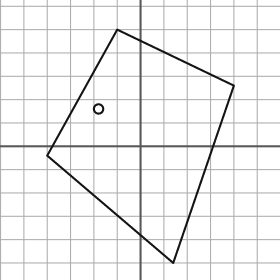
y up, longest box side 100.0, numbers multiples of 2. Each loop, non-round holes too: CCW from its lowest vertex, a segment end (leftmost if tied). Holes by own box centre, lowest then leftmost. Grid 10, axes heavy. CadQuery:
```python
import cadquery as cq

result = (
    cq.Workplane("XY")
    .moveTo(14.0, -50.0)
    .lineTo(40.0, 26.0)
    .lineTo(-10.0, 50.0)
    .lineTo(-40.0, -4.0)
    .close()
    .moveTo(-18.0, 16.0)
    .circle(2.0)
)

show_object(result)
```